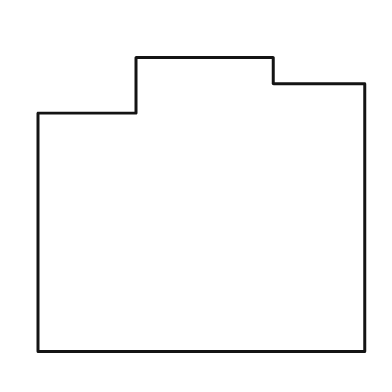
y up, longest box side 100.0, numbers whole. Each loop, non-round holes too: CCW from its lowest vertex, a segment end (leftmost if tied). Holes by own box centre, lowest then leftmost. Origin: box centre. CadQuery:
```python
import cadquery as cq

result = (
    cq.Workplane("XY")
    .moveTo(-50.0, -45.0)
    .lineTo(50.0, -45.0)
    .lineTo(50.0, 37.0)
    .lineTo(22.0, 37.0)
    .lineTo(22.0, 45.0)
    .lineTo(-20.0, 45.0)
    .lineTo(-20.0, 28.0)
    .lineTo(-50.0, 28.0)
    .close()
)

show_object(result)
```